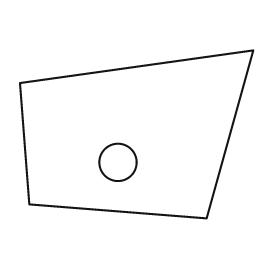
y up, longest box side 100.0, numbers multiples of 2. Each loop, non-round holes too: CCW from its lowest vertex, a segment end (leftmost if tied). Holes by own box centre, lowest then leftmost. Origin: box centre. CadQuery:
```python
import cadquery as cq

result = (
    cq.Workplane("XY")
    .moveTo(30.0, -36.0)
    .lineTo(50.0, 36.0)
    .lineTo(-50.0, 22.0)
    .lineTo(-46.0, -30.0)
    .close()
    .moveTo(-8.0, -12.0)
    .circle(8.0)
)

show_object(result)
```